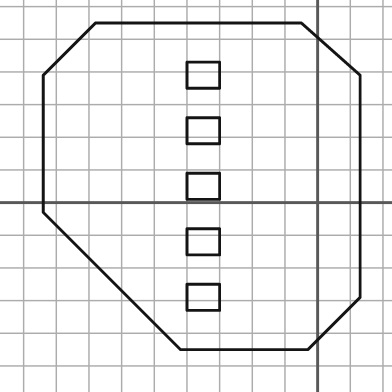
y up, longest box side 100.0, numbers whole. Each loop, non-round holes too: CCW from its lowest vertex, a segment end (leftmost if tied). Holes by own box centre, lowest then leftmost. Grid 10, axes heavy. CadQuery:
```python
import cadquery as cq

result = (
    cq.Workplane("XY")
    .moveTo(-42.0, -45.0)
    .lineTo(-3.0, -45.0)
    .lineTo(13.0, -29.0)
    .lineTo(13.0, 39.0)
    .lineTo(-5.0, 55.0)
    .lineTo(-68.0, 55.0)
    .lineTo(-84.0, 39.0)
    .lineTo(-84.0, -3.0)
    .close()
    .moveTo(-40.0, -33.0)
    .lineTo(-30.0, -33.0)
    .lineTo(-30.0, -25.0)
    .lineTo(-40.0, -25.0)
    .close()
    .moveTo(-40.0, -16.0)
    .lineTo(-30.0, -16.0)
    .lineTo(-30.0, -8.0)
    .lineTo(-40.0, -8.0)
    .close()
    .moveTo(-40.0, 1.0)
    .lineTo(-30.0, 1.0)
    .lineTo(-30.0, 9.0)
    .lineTo(-40.0, 9.0)
    .close()
    .moveTo(-40.0, 18.0)
    .lineTo(-30.0, 18.0)
    .lineTo(-30.0, 26.0)
    .lineTo(-40.0, 26.0)
    .close()
    .moveTo(-40.0, 35.0)
    .lineTo(-30.0, 35.0)
    .lineTo(-30.0, 43.0)
    .lineTo(-40.0, 43.0)
    .close()
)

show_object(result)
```